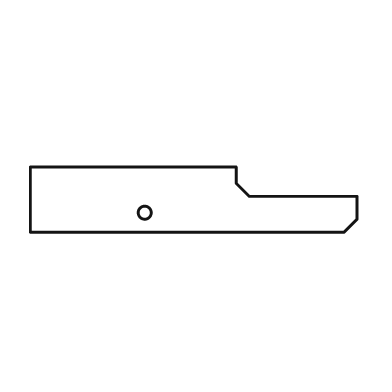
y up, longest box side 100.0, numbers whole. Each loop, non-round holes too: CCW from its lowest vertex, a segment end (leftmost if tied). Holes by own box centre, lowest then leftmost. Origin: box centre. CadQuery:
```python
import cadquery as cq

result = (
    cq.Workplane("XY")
    .moveTo(-50.0, -10.0)
    .lineTo(46.0, -10.0)
    .lineTo(50.0, -6.0)
    .lineTo(50.0, 1.0)
    .lineTo(17.0, 1.0)
    .lineTo(13.0, 5.0)
    .lineTo(13.0, 10.0)
    .lineTo(-50.0, 10.0)
    .close()
    .moveTo(-15.0, -4.0)
    .circle(2.0)
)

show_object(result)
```